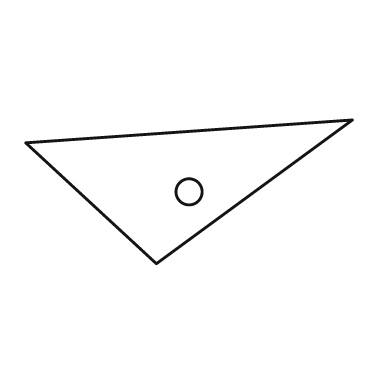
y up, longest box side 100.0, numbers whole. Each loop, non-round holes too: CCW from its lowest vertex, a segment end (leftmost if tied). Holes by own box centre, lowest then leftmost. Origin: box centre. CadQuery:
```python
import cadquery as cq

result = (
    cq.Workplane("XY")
    .moveTo(-10.0, -22.0)
    .lineTo(50.0, 22.0)
    .lineTo(-50.0, 15.0)
    .close()
    .moveTo(0.0, 0.0)
    .circle(4.0)
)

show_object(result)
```